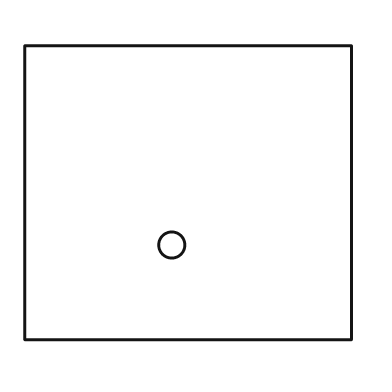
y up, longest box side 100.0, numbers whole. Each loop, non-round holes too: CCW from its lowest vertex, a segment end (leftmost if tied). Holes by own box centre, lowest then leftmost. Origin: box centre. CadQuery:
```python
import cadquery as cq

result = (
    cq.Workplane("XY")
    .moveTo(-50.0, -45.0)
    .lineTo(50.0, -45.0)
    .lineTo(50.0, 45.0)
    .lineTo(-50.0, 45.0)
    .close()
    .moveTo(-5.0, -16.0)
    .circle(4.0)
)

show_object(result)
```